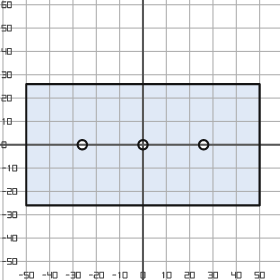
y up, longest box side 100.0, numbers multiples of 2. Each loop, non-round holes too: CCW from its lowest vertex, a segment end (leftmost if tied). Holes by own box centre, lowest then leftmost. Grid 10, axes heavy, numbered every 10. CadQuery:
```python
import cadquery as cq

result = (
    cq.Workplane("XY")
    .moveTo(-50.0, -26.0)
    .lineTo(50.0, -26.0)
    .lineTo(50.0, 26.0)
    .lineTo(-50.0, 26.0)
    .close()
    .moveTo(-26.0, 0.0)
    .circle(2.0)
    .moveTo(0.0, 0.0)
    .circle(2.0)
    .moveTo(26.0, 0.0)
    .circle(2.0)
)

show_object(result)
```